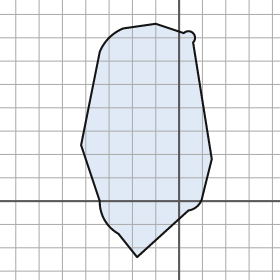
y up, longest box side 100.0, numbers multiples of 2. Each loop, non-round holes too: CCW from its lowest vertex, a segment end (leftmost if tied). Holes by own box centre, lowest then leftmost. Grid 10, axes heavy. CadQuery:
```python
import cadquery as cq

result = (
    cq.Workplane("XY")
    .moveTo(-18.0, -24.0)
    .lineTo(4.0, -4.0)
    .threePointArc((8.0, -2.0), (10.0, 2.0))
    .lineTo(14.0, 18.0)
    .lineTo(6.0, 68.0)
    .threePointArc((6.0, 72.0), (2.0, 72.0))
    .lineTo(-10.0, 76.0)
    .lineTo(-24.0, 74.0)
    .threePointArc((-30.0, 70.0), (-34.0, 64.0))
    .lineTo(-42.0, 24.0)
    .lineTo(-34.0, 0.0)
    .threePointArc((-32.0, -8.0), (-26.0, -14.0))
    .close()
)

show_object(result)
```